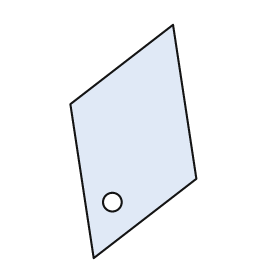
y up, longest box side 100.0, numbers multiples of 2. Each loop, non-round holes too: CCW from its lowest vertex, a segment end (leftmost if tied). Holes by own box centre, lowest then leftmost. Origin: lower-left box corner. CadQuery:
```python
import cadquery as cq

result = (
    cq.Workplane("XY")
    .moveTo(10.0, 0.0)
    .lineTo(54.0, 34.0)
    .lineTo(44.0, 100.0)
    .lineTo(0.0, 66.0)
    .close()
    .moveTo(18.0, 24.0)
    .circle(4.0)
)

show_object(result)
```